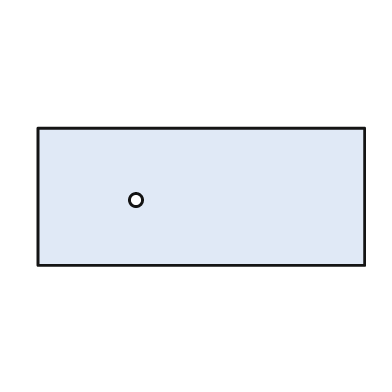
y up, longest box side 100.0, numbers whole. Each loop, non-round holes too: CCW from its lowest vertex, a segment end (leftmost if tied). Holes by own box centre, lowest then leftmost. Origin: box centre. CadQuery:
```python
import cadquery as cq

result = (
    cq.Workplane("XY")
    .moveTo(-50.0, -21.0)
    .lineTo(50.0, -21.0)
    .lineTo(50.0, 21.0)
    .lineTo(-50.0, 21.0)
    .close()
    .moveTo(-20.0, -1.0)
    .circle(2.0)
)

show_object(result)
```